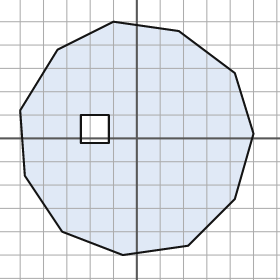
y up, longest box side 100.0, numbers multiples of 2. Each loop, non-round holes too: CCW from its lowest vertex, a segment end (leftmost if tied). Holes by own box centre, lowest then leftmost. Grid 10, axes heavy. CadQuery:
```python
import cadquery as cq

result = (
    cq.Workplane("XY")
    .moveTo(-6.0, -50.0)
    .lineTo(22.0, -46.0)
    .lineTo(42.0, -26.0)
    .lineTo(50.0, 2.0)
    .lineTo(42.0, 28.0)
    .lineTo(18.0, 46.0)
    .lineTo(-10.0, 50.0)
    .lineTo(-34.0, 38.0)
    .lineTo(-50.0, 12.0)
    .lineTo(-48.0, -16.0)
    .lineTo(-32.0, -40.0)
    .close()
    .moveTo(-24.0, -2.0)
    .lineTo(-12.0, -2.0)
    .lineTo(-12.0, 10.0)
    .lineTo(-24.0, 10.0)
    .close()
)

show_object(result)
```